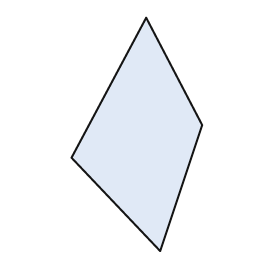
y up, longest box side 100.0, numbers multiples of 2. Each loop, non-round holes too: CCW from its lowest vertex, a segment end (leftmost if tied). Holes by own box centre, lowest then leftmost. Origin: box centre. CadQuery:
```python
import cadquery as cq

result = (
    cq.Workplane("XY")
    .moveTo(10.0, -50.0)
    .lineTo(28.0, 4.0)
    .lineTo(4.0, 50.0)
    .lineTo(-28.0, -10.0)
    .close()
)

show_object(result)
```